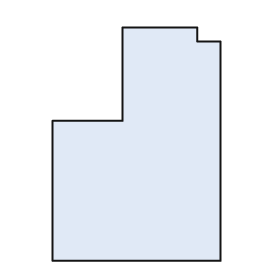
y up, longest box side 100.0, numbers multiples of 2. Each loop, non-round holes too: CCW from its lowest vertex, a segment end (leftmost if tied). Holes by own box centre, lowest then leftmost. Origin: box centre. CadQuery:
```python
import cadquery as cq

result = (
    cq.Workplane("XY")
    .moveTo(-36.0, -50.0)
    .lineTo(36.0, -50.0)
    .lineTo(36.0, 44.0)
    .lineTo(26.0, 44.0)
    .lineTo(26.0, 50.0)
    .lineTo(-6.0, 50.0)
    .lineTo(-6.0, 10.0)
    .lineTo(-36.0, 10.0)
    .close()
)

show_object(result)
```